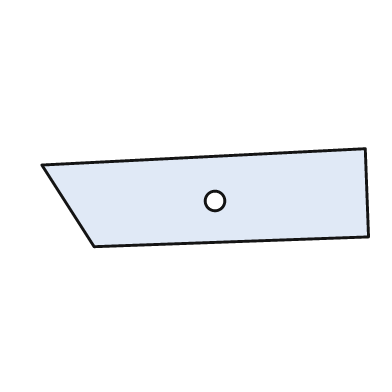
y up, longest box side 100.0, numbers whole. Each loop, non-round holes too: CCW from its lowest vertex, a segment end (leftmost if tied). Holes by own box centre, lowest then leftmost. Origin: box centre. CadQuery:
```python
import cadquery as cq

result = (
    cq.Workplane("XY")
    .moveTo(-34.0, -15.0)
    .lineTo(50.0, -12.0)
    .lineTo(49.0, 15.0)
    .lineTo(-50.0, 10.0)
    .close()
    .moveTo(3.0, -1.0)
    .circle(3.0)
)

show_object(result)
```